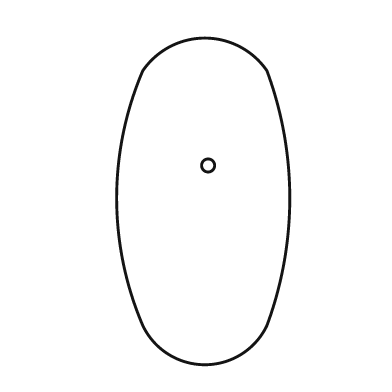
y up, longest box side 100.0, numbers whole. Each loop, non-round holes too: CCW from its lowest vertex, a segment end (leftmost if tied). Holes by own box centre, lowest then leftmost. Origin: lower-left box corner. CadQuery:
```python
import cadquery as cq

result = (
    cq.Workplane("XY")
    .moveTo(8.0, 12.0)
    .threePointArc((27.0, 0.0), (46.0, 12.0))
    .threePointArc((53.0, 51.0), (46.0, 90.0))
    .threePointArc((27.0, 100.0), (8.0, 90.0))
    .threePointArc((0.0, 51.0), (8.0, 12.0))
    .close()
    .moveTo(28.0, 61.0)
    .circle(2.0)
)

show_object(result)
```